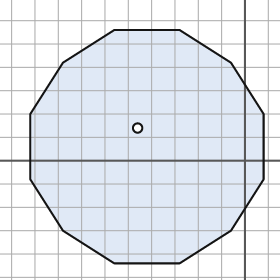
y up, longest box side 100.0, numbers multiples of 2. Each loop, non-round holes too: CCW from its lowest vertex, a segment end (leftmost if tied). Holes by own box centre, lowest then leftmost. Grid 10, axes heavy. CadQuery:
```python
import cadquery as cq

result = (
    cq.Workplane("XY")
    .moveTo(-56.0, -44.0)
    .lineTo(-28.0, -44.0)
    .lineTo(-6.0, -30.0)
    .lineTo(8.0, -8.0)
    .lineTo(8.0, 20.0)
    .lineTo(-6.0, 42.0)
    .lineTo(-28.0, 56.0)
    .lineTo(-56.0, 56.0)
    .lineTo(-78.0, 42.0)
    .lineTo(-92.0, 20.0)
    .lineTo(-92.0, -8.0)
    .lineTo(-78.0, -30.0)
    .close()
    .moveTo(-46.0, 14.0)
    .circle(2.0)
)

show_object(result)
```